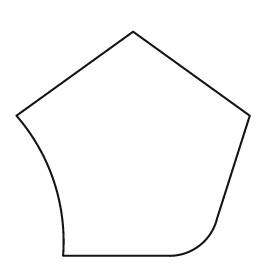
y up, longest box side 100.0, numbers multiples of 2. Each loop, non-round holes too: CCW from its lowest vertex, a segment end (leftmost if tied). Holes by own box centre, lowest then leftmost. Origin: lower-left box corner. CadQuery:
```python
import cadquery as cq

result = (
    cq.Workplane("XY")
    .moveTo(20.0, 0.0)
    .lineTo(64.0, 0.0)
    .threePointArc((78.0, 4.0), (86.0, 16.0))
    .lineTo(100.0, 60.0)
    .lineTo(50.0, 96.0)
    .lineTo(0.0, 60.0)
    .threePointArc((16.0, 32.0), (20.0, 0.0))
    .close()
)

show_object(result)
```